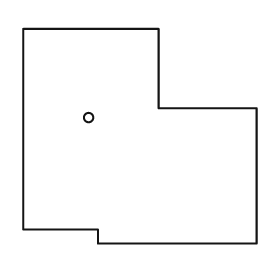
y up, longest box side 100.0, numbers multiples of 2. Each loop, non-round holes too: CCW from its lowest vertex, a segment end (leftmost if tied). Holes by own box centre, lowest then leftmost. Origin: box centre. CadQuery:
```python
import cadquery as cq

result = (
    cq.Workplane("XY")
    .moveTo(-18.0, -46.0)
    .lineTo(50.0, -46.0)
    .lineTo(50.0, 12.0)
    .lineTo(8.0, 12.0)
    .lineTo(8.0, 46.0)
    .lineTo(-50.0, 46.0)
    .lineTo(-50.0, -40.0)
    .lineTo(-18.0, -40.0)
    .close()
    .moveTo(-22.0, 8.0)
    .circle(2.0)
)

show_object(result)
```